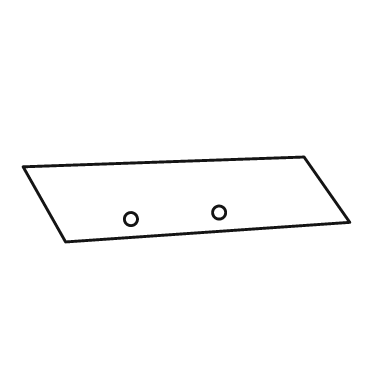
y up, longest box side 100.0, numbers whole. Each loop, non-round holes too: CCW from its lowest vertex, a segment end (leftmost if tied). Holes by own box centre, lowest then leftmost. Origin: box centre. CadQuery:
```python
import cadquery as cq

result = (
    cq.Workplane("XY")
    .moveTo(-37.0, -13.0)
    .lineTo(50.0, -7.0)
    .lineTo(36.0, 13.0)
    .lineTo(-50.0, 10.0)
    .close()
    .moveTo(-17.0, -6.0)
    .circle(2.0)
    .moveTo(10.0, -4.0)
    .circle(2.0)
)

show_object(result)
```